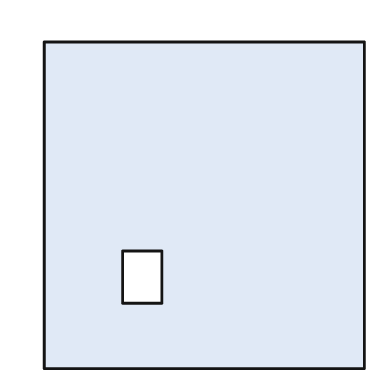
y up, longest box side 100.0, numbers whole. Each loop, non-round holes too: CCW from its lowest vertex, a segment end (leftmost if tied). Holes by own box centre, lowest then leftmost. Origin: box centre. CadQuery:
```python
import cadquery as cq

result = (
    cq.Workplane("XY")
    .moveTo(-49.0, -50.0)
    .lineTo(49.0, -50.0)
    .lineTo(49.0, 50.0)
    .lineTo(-49.0, 50.0)
    .close()
    .moveTo(-25.0, -30.0)
    .lineTo(-13.0, -30.0)
    .lineTo(-13.0, -14.0)
    .lineTo(-25.0, -14.0)
    .close()
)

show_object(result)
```